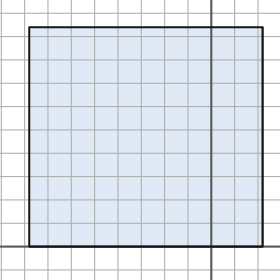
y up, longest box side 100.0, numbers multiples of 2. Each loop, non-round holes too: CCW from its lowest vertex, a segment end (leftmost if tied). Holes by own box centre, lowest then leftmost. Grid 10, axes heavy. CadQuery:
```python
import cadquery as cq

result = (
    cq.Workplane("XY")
    .moveTo(-78.0, 0.0)
    .lineTo(22.0, 0.0)
    .lineTo(22.0, 94.0)
    .lineTo(-78.0, 94.0)
    .close()
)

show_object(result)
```